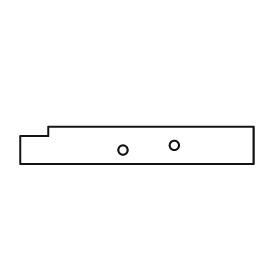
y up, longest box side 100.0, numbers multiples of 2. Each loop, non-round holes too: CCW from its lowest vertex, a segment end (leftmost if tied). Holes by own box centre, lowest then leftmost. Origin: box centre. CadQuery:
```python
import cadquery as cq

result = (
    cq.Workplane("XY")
    .moveTo(-50.0, -8.0)
    .lineTo(50.0, -8.0)
    .lineTo(50.0, 8.0)
    .lineTo(-38.0, 8.0)
    .lineTo(-38.0, 4.0)
    .lineTo(-50.0, 4.0)
    .close()
    .moveTo(-6.0, -2.0)
    .circle(2.0)
    .moveTo(16.0, 0.0)
    .circle(2.0)
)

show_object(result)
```